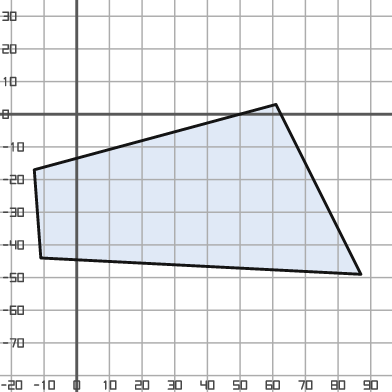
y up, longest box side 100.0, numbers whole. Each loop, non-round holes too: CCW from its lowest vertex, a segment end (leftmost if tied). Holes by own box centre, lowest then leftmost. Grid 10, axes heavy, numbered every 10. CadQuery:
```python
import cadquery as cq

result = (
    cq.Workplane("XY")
    .moveTo(87.0, -49.0)
    .lineTo(61.0, 3.0)
    .lineTo(-13.0, -17.0)
    .lineTo(-11.0, -44.0)
    .close()
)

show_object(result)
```